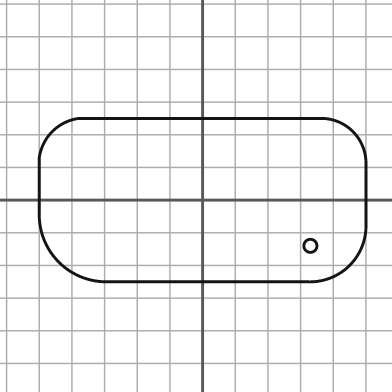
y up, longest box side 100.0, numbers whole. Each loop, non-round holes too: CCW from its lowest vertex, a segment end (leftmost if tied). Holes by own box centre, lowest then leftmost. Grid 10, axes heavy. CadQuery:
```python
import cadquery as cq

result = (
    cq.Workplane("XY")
    .moveTo(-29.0, -25.0)
    .lineTo(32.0, -25.0)
    .threePointArc((45.0, -20.0), (50.0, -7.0))
    .lineTo(50.0, 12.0)
    .threePointArc((46.0, 21.0), (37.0, 25.0))
    .lineTo(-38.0, 25.0)
    .threePointArc((-46.0, 21.0), (-50.0, 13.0))
    .lineTo(-50.0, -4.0)
    .threePointArc((-44.0, -19.0), (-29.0, -25.0))
    .close()
    .moveTo(33.0, -14.0)
    .circle(2.0)
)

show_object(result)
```